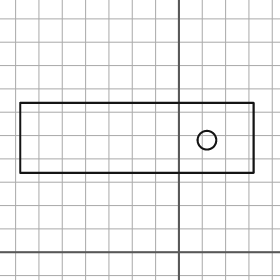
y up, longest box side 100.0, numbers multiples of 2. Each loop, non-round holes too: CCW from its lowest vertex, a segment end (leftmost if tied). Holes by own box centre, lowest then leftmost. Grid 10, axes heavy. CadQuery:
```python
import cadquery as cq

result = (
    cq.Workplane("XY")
    .moveTo(-68.0, 34.0)
    .lineTo(32.0, 34.0)
    .lineTo(32.0, 64.0)
    .lineTo(-68.0, 64.0)
    .close()
    .moveTo(12.0, 48.0)
    .circle(4.0)
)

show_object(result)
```